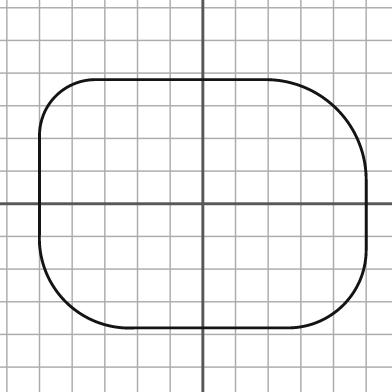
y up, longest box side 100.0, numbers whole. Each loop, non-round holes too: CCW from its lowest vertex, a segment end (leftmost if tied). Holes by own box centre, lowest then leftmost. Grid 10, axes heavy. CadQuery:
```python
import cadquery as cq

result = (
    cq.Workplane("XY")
    .moveTo(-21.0, -38.0)
    .lineTo(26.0, -38.0)
    .threePointArc((43.0, -31.0), (50.0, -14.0))
    .lineTo(50.0, 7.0)
    .threePointArc((41.0, 29.0), (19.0, 38.0))
    .lineTo(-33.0, 38.0)
    .threePointArc((-45.0, 33.0), (-50.0, 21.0))
    .lineTo(-50.0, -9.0)
    .threePointArc((-42.0, -30.0), (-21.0, -38.0))
    .close()
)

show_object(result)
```